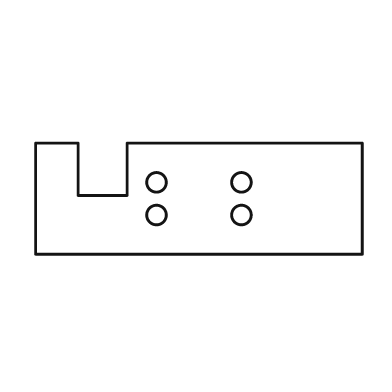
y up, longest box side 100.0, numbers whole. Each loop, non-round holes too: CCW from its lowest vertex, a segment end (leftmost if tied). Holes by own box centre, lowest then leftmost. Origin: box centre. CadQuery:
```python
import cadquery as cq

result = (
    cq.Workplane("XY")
    .moveTo(-50.0, -17.0)
    .lineTo(50.0, -17.0)
    .lineTo(50.0, 17.0)
    .lineTo(-22.0, 17.0)
    .lineTo(-22.0, 1.0)
    .lineTo(-37.0, 1.0)
    .lineTo(-37.0, 17.0)
    .lineTo(-50.0, 17.0)
    .close()
    .moveTo(-13.0, -5.0)
    .circle(3.0)
    .moveTo(13.0, -5.0)
    .circle(3.0)
    .moveTo(-13.0, 5.0)
    .circle(3.0)
    .moveTo(13.0, 5.0)
    .circle(3.0)
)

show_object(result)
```